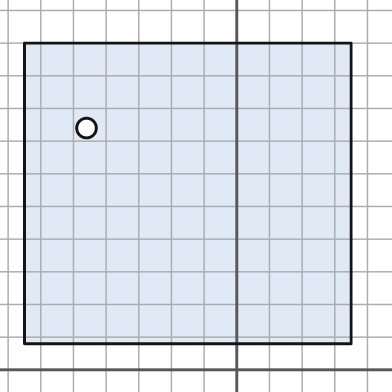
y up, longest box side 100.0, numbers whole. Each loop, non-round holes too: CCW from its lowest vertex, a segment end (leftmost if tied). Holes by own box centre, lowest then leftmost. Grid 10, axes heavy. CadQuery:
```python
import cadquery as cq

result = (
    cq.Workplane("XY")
    .moveTo(-65.0, 8.0)
    .lineTo(35.0, 8.0)
    .lineTo(35.0, 100.0)
    .lineTo(-65.0, 100.0)
    .close()
    .moveTo(-46.0, 74.0)
    .circle(3.0)
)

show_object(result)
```